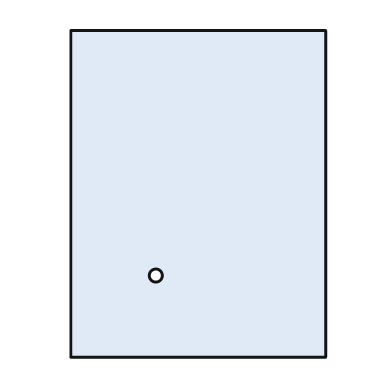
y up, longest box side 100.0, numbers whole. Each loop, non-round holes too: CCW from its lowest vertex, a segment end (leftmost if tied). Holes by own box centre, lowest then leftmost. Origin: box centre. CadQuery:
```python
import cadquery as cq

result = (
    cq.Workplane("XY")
    .moveTo(-39.0, -50.0)
    .lineTo(39.0, -50.0)
    .lineTo(39.0, 50.0)
    .lineTo(-39.0, 50.0)
    .close()
    .moveTo(-13.0, -25.0)
    .circle(2.0)
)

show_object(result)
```